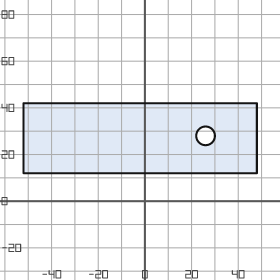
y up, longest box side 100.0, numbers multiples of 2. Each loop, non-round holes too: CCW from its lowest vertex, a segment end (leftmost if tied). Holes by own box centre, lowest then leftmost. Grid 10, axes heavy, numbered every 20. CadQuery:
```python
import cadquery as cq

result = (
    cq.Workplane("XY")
    .moveTo(-52.0, 12.0)
    .lineTo(48.0, 12.0)
    .lineTo(48.0, 42.0)
    .lineTo(-52.0, 42.0)
    .close()
    .moveTo(26.0, 28.0)
    .circle(4.0)
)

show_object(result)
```